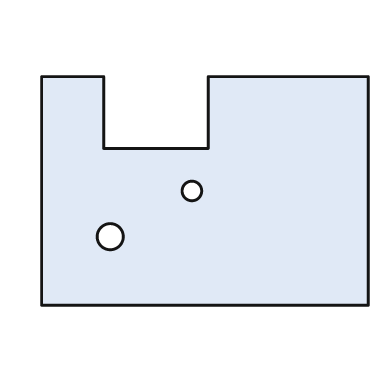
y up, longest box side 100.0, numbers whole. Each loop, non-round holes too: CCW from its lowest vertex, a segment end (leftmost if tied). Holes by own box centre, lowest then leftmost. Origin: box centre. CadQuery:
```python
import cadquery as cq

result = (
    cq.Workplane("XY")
    .moveTo(-50.0, -35.0)
    .lineTo(50.0, -35.0)
    .lineTo(50.0, 35.0)
    .lineTo(1.0, 35.0)
    .lineTo(1.0, 13.0)
    .lineTo(-31.0, 13.0)
    .lineTo(-31.0, 35.0)
    .lineTo(-50.0, 35.0)
    .close()
    .moveTo(-29.0, -14.0)
    .circle(4.0)
    .moveTo(-4.0, 0.0)
    .circle(3.0)
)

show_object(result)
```